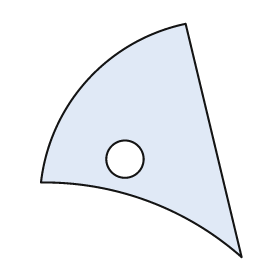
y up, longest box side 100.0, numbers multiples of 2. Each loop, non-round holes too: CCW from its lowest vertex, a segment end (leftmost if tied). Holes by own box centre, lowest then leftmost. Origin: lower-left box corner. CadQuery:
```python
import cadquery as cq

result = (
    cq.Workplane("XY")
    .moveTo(86.0, 0.0)
    .lineTo(62.0, 100.0)
    .threePointArc((20.0, 76.0), (0.0, 32.0))
    .threePointArc((46.0, 24.0), (86.0, 0.0))
    .close()
    .moveTo(36.0, 42.0)
    .circle(8.0)
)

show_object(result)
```